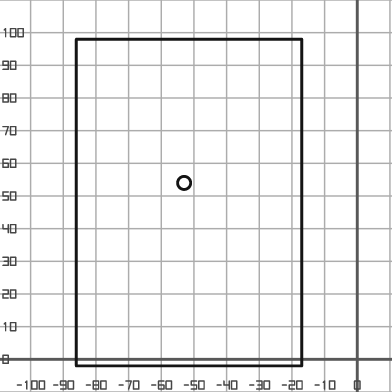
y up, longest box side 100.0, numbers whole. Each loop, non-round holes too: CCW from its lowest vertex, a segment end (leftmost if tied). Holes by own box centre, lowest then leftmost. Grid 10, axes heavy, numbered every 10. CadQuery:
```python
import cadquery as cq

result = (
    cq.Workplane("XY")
    .moveTo(-86.0, -2.0)
    .lineTo(-17.0, -2.0)
    .lineTo(-17.0, 98.0)
    .lineTo(-86.0, 98.0)
    .close()
    .moveTo(-53.0, 54.0)
    .circle(2.0)
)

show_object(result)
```